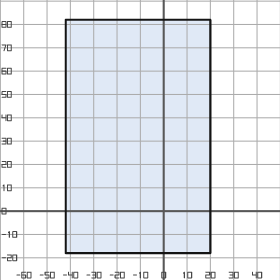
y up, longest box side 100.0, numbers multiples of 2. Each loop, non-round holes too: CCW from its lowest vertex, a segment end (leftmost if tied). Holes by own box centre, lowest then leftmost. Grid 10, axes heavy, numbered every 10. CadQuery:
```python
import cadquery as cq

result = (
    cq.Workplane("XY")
    .moveTo(-42.0, -18.0)
    .lineTo(20.0, -18.0)
    .lineTo(20.0, 82.0)
    .lineTo(-42.0, 82.0)
    .close()
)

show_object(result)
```